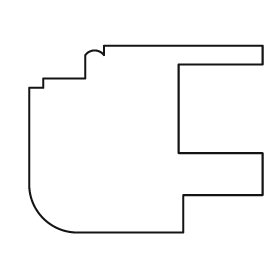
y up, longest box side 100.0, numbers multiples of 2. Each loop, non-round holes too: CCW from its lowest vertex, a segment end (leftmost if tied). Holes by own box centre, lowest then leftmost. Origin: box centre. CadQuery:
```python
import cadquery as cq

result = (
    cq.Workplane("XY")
    .moveTo(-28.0, -40.0)
    .lineTo(16.0, -40.0)
    .lineTo(16.0, -24.0)
    .lineTo(50.0, -24.0)
    .lineTo(50.0, -6.0)
    .lineTo(14.0, -6.0)
    .lineTo(14.0, 32.0)
    .lineTo(50.0, 32.0)
    .lineTo(50.0, 40.0)
    .lineTo(-18.0, 40.0)
    .lineTo(-18.0, 36.0)
    .threePointArc((-22.0, 38.0), (-26.0, 36.0))
    .lineTo(-26.0, 26.0)
    .lineTo(-44.0, 26.0)
    .lineTo(-44.0, 22.0)
    .lineTo(-50.0, 22.0)
    .lineTo(-50.0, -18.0)
    .threePointArc((-44.0, -34.0), (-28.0, -40.0))
    .close()
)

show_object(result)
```